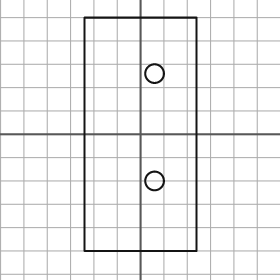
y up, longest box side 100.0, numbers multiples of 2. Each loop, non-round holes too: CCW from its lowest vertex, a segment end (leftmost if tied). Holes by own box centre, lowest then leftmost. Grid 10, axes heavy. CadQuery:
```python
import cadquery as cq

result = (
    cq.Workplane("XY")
    .moveTo(-24.0, -50.0)
    .lineTo(24.0, -50.0)
    .lineTo(24.0, 50.0)
    .lineTo(-24.0, 50.0)
    .close()
    .moveTo(6.0, -20.0)
    .circle(4.0)
    .moveTo(6.0, 26.0)
    .circle(4.0)
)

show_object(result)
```